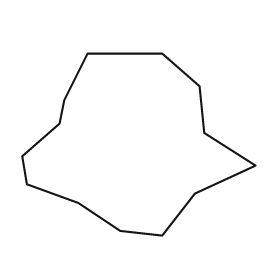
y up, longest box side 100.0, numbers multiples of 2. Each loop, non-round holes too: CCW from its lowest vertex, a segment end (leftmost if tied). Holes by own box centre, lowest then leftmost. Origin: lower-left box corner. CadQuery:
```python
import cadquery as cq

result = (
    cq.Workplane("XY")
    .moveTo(60.0, 0.0)
    .lineTo(74.0, 18.0)
    .lineTo(100.0, 30.0)
    .lineTo(78.0, 44.0)
    .lineTo(76.0, 64.0)
    .lineTo(60.0, 78.0)
    .lineTo(28.0, 78.0)
    .lineTo(18.0, 58.0)
    .lineTo(16.0, 48.0)
    .lineTo(0.0, 34.0)
    .lineTo(2.0, 22.0)
    .lineTo(24.0, 14.0)
    .lineTo(42.0, 2.0)
    .close()
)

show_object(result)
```